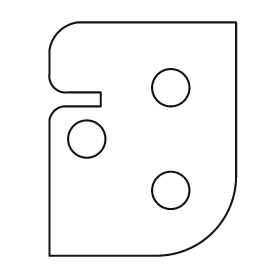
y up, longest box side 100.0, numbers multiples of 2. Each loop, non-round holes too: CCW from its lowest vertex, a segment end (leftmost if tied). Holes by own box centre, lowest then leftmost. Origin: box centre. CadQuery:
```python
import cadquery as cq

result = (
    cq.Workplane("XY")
    .moveTo(-40.0, -50.0)
    .lineTo(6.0, -50.0)
    .threePointArc((30.0, -40.0), (40.0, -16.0))
    .lineTo(40.0, 50.0)
    .lineTo(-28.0, 50.0)
    .threePointArc((-36.0, 46.0), (-40.0, 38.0))
    .lineTo(-40.0, 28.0)
    .threePointArc((-38.0, 22.0), (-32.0, 20.0))
    .lineTo(-18.0, 20.0)
    .lineTo(-18.0, 14.0)
    .lineTo(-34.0, 14.0)
    .threePointArc((-38.0, 12.0), (-40.0, 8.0))
    .close()
    .moveTo(12.0, -22.0)
    .circle(8.0)
    .moveTo(-24.0, 0.0)
    .circle(8.0)
    .moveTo(12.0, 22.0)
    .circle(8.0)
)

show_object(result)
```